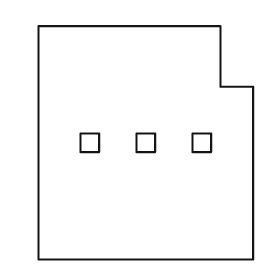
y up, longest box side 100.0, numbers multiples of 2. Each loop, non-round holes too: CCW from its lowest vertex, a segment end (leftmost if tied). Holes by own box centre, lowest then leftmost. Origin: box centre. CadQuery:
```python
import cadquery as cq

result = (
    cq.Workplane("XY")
    .moveTo(-46.0, -50.0)
    .lineTo(46.0, -50.0)
    .lineTo(46.0, 24.0)
    .lineTo(32.0, 24.0)
    .lineTo(32.0, 50.0)
    .lineTo(-46.0, 50.0)
    .close()
    .moveTo(-28.0, -4.0)
    .lineTo(-20.0, -4.0)
    .lineTo(-20.0, 4.0)
    .lineTo(-28.0, 4.0)
    .close()
    .moveTo(-4.0, -4.0)
    .lineTo(4.0, -4.0)
    .lineTo(4.0, 4.0)
    .lineTo(-4.0, 4.0)
    .close()
    .moveTo(20.0, -4.0)
    .lineTo(28.0, -4.0)
    .lineTo(28.0, 4.0)
    .lineTo(20.0, 4.0)
    .close()
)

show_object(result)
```